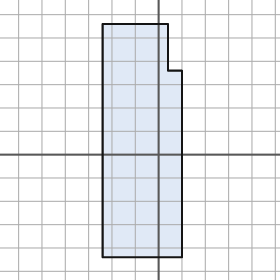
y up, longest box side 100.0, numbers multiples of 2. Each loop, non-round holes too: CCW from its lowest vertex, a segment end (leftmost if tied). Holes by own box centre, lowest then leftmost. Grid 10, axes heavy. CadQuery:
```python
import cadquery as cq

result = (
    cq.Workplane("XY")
    .moveTo(-24.0, -44.0)
    .lineTo(10.0, -44.0)
    .lineTo(10.0, 36.0)
    .lineTo(4.0, 36.0)
    .lineTo(4.0, 56.0)
    .lineTo(-24.0, 56.0)
    .close()
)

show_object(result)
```